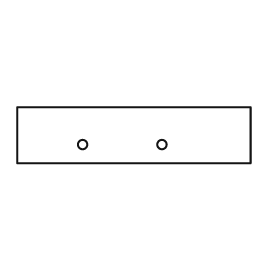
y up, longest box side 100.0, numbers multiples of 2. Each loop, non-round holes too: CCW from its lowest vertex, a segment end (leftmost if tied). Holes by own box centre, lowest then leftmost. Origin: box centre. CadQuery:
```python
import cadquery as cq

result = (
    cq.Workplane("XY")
    .moveTo(-50.0, -12.0)
    .lineTo(50.0, -12.0)
    .lineTo(50.0, 12.0)
    .lineTo(-50.0, 12.0)
    .close()
    .moveTo(-22.0, -4.0)
    .circle(2.0)
    .moveTo(12.0, -4.0)
    .circle(2.0)
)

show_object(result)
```